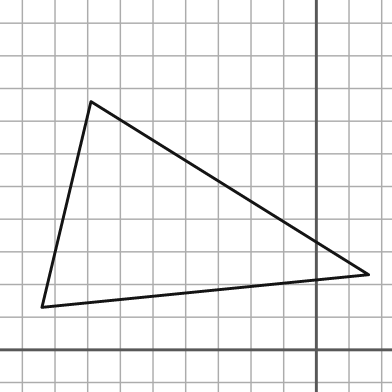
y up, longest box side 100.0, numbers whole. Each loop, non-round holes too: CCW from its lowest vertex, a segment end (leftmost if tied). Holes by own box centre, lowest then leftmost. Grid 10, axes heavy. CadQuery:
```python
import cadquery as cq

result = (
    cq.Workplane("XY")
    .moveTo(-84.0, 13.0)
    .lineTo(16.0, 23.0)
    .lineTo(-69.0, 76.0)
    .close()
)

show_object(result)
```